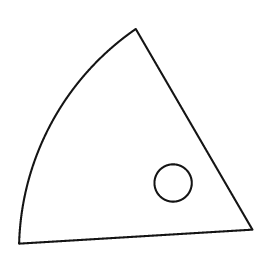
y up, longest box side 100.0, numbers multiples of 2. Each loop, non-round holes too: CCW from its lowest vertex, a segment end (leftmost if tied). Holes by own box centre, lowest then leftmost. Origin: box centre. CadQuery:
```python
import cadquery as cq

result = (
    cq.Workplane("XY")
    .moveTo(-50.0, -46.0)
    .lineTo(50.0, -40.0)
    .lineTo(0.0, 46.0)
    .threePointArc((-36.0, 6.0), (-50.0, -46.0))
    .close()
    .moveTo(16.0, -20.0)
    .circle(8.0)
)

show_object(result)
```